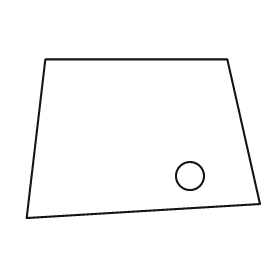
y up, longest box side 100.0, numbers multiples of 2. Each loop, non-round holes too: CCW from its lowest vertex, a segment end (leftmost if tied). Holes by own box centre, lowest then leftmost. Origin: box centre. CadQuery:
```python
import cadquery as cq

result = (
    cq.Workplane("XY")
    .moveTo(-50.0, -34.0)
    .lineTo(50.0, -28.0)
    .lineTo(36.0, 34.0)
    .lineTo(-42.0, 34.0)
    .close()
    .moveTo(20.0, -16.0)
    .circle(6.0)
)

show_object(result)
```